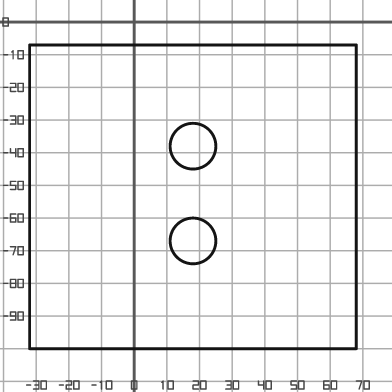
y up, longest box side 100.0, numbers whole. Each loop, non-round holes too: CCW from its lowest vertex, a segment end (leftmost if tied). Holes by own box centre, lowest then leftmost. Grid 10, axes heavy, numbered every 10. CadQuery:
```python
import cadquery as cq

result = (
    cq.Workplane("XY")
    .moveTo(-32.0, -100.0)
    .lineTo(68.0, -100.0)
    .lineTo(68.0, -7.0)
    .lineTo(-32.0, -7.0)
    .close()
    .moveTo(18.0, -67.0)
    .circle(7.0)
    .moveTo(18.0, -38.0)
    .circle(7.0)
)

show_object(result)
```